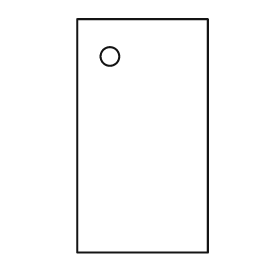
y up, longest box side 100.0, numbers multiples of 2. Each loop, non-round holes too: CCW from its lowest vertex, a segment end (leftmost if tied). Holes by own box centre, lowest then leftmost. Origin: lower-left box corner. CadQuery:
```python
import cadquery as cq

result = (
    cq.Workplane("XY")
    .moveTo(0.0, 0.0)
    .lineTo(56.0, 0.0)
    .lineTo(56.0, 100.0)
    .lineTo(0.0, 100.0)
    .close()
    .moveTo(14.0, 84.0)
    .circle(4.0)
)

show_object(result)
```